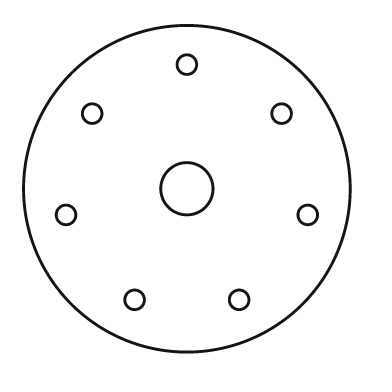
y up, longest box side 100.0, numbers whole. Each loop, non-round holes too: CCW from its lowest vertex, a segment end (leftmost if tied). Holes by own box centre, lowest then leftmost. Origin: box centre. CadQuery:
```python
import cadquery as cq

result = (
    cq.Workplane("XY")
    .moveTo(0.0, 0.0)
    .circle(50.0)
    .moveTo(-16.0, -34.0)
    .circle(3.0)
    .moveTo(16.0, -34.0)
    .circle(3.0)
    .moveTo(-37.0, -8.0)
    .circle(3.0)
    .moveTo(37.0, -8.0)
    .circle(3.0)
    .moveTo(0.0, 0.0)
    .circle(8.0)
    .moveTo(-29.0, 23.0)
    .circle(3.0)
    .moveTo(29.0, 23.0)
    .circle(3.0)
    .moveTo(0.0, 38.0)
    .circle(3.0)
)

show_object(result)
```